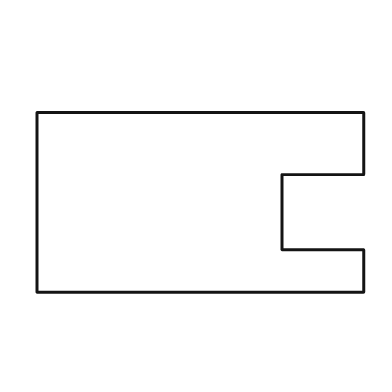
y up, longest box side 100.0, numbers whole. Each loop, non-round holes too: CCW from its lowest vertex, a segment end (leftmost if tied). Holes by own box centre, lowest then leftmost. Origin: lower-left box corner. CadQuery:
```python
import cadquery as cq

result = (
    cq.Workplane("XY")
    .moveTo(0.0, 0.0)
    .lineTo(100.0, 0.0)
    .lineTo(100.0, 13.0)
    .lineTo(75.0, 13.0)
    .lineTo(75.0, 36.0)
    .lineTo(100.0, 36.0)
    .lineTo(100.0, 55.0)
    .lineTo(0.0, 55.0)
    .close()
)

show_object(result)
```